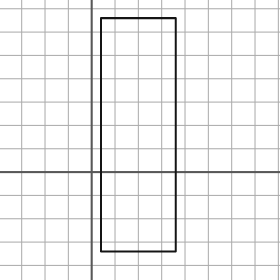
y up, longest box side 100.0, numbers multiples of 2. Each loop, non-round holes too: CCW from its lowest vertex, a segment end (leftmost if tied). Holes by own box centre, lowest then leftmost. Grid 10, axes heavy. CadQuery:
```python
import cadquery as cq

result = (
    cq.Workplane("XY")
    .moveTo(4.0, -34.0)
    .lineTo(36.0, -34.0)
    .lineTo(36.0, 66.0)
    .lineTo(4.0, 66.0)
    .close()
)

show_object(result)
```